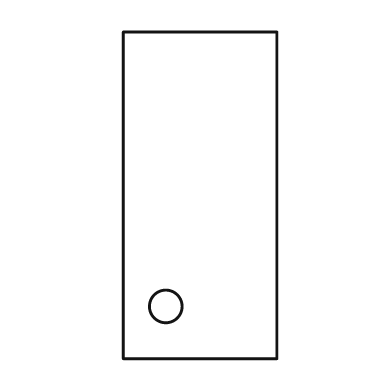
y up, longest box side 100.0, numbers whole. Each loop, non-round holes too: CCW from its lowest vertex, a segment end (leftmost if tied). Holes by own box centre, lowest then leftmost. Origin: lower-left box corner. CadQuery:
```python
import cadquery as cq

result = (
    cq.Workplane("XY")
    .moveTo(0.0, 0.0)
    .lineTo(47.0, 0.0)
    .lineTo(47.0, 100.0)
    .lineTo(0.0, 100.0)
    .close()
    .moveTo(13.0, 16.0)
    .circle(5.0)
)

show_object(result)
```